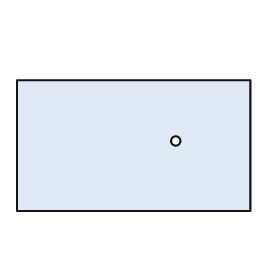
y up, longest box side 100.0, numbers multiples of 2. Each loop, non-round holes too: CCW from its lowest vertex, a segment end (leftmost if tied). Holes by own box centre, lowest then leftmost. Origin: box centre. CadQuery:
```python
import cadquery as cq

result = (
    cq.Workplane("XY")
    .moveTo(-50.0, -28.0)
    .lineTo(50.0, -28.0)
    .lineTo(50.0, 28.0)
    .lineTo(-50.0, 28.0)
    .close()
    .moveTo(18.0, 2.0)
    .circle(2.0)
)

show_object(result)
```